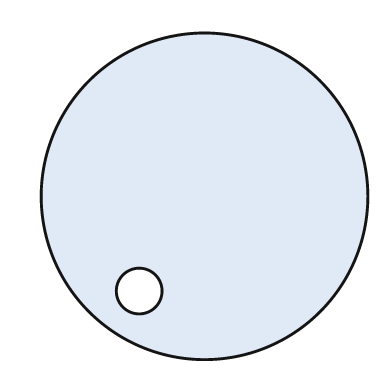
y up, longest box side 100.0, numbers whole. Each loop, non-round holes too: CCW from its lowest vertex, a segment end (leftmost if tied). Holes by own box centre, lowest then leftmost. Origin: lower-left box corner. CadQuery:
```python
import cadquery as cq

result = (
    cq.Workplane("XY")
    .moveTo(50.0, 50.0)
    .circle(50.0)
    .moveTo(30.0, 21.0)
    .circle(7.0)
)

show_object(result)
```